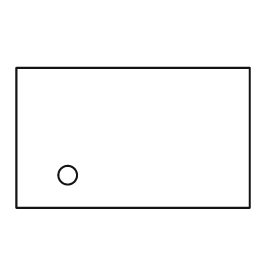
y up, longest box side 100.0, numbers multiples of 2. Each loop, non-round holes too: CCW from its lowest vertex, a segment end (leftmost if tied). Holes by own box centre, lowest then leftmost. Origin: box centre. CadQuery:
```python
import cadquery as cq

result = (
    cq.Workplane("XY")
    .moveTo(-50.0, -30.0)
    .lineTo(50.0, -30.0)
    .lineTo(50.0, 30.0)
    .lineTo(-50.0, 30.0)
    .close()
    .moveTo(-28.0, -16.0)
    .circle(4.0)
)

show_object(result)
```